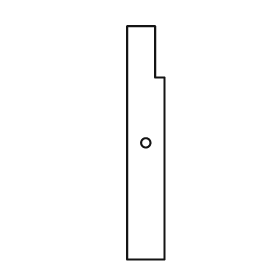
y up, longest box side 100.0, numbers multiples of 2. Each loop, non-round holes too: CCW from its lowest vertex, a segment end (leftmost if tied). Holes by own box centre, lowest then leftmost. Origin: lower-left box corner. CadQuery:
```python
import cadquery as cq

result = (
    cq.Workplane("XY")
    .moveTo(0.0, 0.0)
    .lineTo(16.0, 0.0)
    .lineTo(16.0, 78.0)
    .lineTo(12.0, 78.0)
    .lineTo(12.0, 100.0)
    .lineTo(0.0, 100.0)
    .close()
    .moveTo(8.0, 50.0)
    .circle(2.0)
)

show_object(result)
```